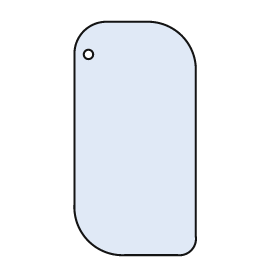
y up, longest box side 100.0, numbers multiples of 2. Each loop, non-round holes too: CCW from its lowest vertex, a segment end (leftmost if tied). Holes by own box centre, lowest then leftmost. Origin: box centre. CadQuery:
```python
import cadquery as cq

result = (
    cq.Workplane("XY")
    .moveTo(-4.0, -50.0)
    .lineTo(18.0, -50.0)
    .threePointArc((24.0, -48.0), (26.0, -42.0))
    .lineTo(26.0, 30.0)
    .threePointArc((20.0, 44.0), (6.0, 50.0))
    .lineTo(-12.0, 50.0)
    .threePointArc((-22.0, 46.0), (-26.0, 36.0))
    .lineTo(-26.0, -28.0)
    .threePointArc((-20.0, -44.0), (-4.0, -50.0))
    .close()
    .moveTo(-20.0, 36.0)
    .circle(2.0)
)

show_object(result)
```